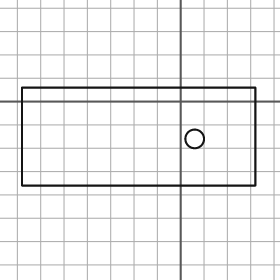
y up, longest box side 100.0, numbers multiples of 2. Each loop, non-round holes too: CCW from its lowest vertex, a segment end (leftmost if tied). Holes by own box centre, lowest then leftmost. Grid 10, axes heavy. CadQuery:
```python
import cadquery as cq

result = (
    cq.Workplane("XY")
    .moveTo(-68.0, -36.0)
    .lineTo(32.0, -36.0)
    .lineTo(32.0, 6.0)
    .lineTo(-68.0, 6.0)
    .close()
    .moveTo(6.0, -16.0)
    .circle(4.0)
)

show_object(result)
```